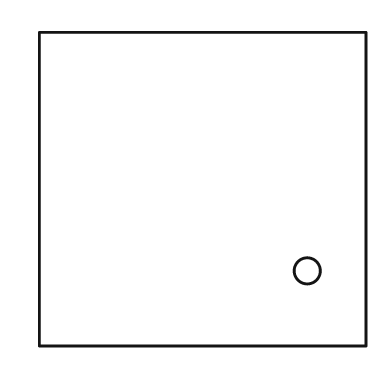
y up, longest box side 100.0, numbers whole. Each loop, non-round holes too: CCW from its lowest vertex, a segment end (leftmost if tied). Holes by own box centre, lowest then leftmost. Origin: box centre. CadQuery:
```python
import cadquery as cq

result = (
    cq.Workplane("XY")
    .moveTo(-50.0, -48.0)
    .lineTo(50.0, -48.0)
    .lineTo(50.0, 48.0)
    .lineTo(-50.0, 48.0)
    .close()
    .moveTo(32.0, -25.0)
    .circle(4.0)
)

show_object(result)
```